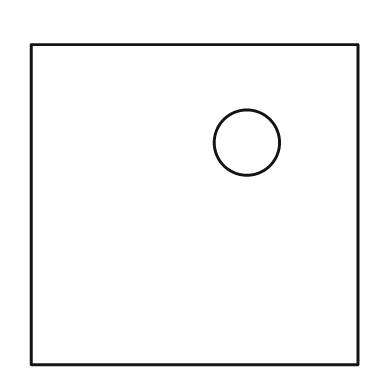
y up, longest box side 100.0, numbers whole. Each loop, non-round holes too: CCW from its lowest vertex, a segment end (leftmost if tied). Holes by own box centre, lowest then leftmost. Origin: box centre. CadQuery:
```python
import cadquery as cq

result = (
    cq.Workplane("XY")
    .moveTo(-50.0, -49.0)
    .lineTo(50.0, -49.0)
    .lineTo(50.0, 49.0)
    .lineTo(-50.0, 49.0)
    .close()
    .moveTo(16.0, 19.0)
    .circle(10.0)
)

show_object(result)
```